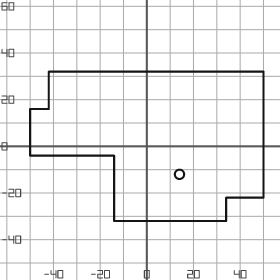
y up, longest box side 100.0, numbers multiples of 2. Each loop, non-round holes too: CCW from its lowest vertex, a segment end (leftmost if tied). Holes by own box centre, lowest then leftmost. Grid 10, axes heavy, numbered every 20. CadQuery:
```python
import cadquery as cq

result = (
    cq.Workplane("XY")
    .moveTo(-14.0, -32.0)
    .lineTo(34.0, -32.0)
    .lineTo(34.0, -22.0)
    .lineTo(50.0, -22.0)
    .lineTo(50.0, 32.0)
    .lineTo(-42.0, 32.0)
    .lineTo(-42.0, 16.0)
    .lineTo(-50.0, 16.0)
    .lineTo(-50.0, -4.0)
    .lineTo(-14.0, -4.0)
    .close()
    .moveTo(14.0, -12.0)
    .circle(2.0)
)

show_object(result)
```